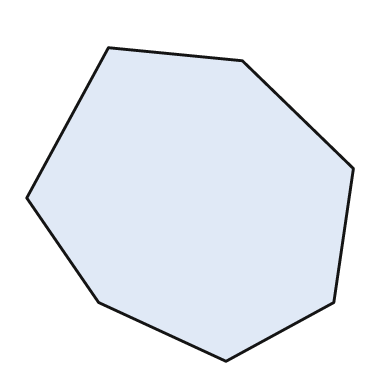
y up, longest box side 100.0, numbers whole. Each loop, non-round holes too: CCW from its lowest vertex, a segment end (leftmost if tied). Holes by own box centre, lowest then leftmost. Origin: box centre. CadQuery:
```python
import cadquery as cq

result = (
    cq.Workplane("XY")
    .moveTo(11.0, -48.0)
    .lineTo(44.0, -30.0)
    .lineTo(50.0, 11.0)
    .lineTo(16.0, 44.0)
    .lineTo(-25.0, 48.0)
    .lineTo(-50.0, 2.0)
    .lineTo(-28.0, -30.0)
    .close()
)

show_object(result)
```